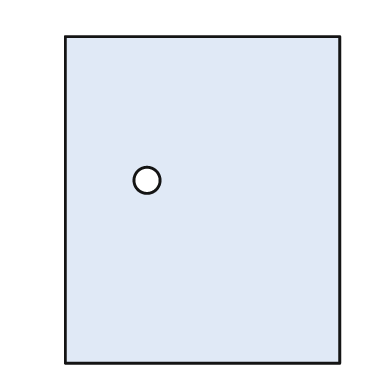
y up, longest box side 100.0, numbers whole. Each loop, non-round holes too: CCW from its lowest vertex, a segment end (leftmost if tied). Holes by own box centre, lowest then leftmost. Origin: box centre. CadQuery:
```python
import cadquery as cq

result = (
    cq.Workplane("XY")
    .moveTo(-42.0, -50.0)
    .lineTo(42.0, -50.0)
    .lineTo(42.0, 50.0)
    .lineTo(-42.0, 50.0)
    .close()
    .moveTo(-17.0, 6.0)
    .circle(4.0)
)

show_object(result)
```